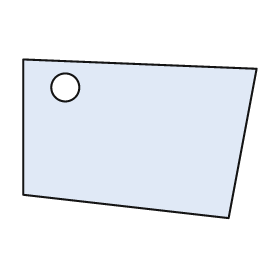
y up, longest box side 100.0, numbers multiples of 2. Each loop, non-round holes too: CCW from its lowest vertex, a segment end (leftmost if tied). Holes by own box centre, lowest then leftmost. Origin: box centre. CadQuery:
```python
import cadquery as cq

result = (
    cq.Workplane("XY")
    .moveTo(38.0, -34.0)
    .lineTo(50.0, 30.0)
    .lineTo(-50.0, 34.0)
    .lineTo(-50.0, -24.0)
    .close()
    .moveTo(-32.0, 22.0)
    .circle(6.0)
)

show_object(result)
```